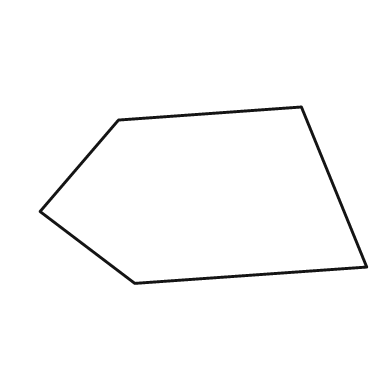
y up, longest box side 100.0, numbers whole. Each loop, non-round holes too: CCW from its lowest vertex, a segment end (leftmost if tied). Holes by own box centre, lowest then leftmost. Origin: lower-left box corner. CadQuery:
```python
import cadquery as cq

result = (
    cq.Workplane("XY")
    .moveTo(29.0, 0.0)
    .lineTo(100.0, 5.0)
    .lineTo(80.0, 54.0)
    .lineTo(24.0, 50.0)
    .lineTo(0.0, 22.0)
    .close()
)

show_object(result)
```